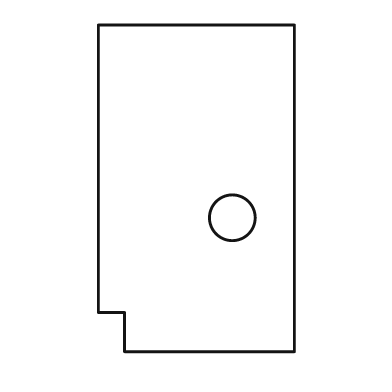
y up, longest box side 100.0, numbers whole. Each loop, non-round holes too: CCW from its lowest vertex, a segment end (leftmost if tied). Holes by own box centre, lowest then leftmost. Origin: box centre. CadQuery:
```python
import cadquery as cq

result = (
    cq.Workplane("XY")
    .moveTo(-22.0, -50.0)
    .lineTo(30.0, -50.0)
    .lineTo(30.0, 50.0)
    .lineTo(-30.0, 50.0)
    .lineTo(-30.0, -38.0)
    .lineTo(-22.0, -38.0)
    .close()
    .moveTo(11.0, -9.0)
    .circle(7.0)
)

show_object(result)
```